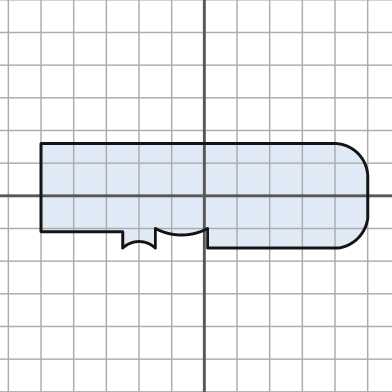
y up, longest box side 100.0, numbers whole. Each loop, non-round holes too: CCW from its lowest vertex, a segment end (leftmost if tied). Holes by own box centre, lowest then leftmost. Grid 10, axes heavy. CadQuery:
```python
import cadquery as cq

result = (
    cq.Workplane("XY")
    .moveTo(-25.0, -16.0)
    .threePointArc((-20.0, -14.0), (-15.0, -16.0))
    .lineTo(-15.0, -10.0)
    .threePointArc((-7.0, -12.0), (1.0, -10.0))
    .lineTo(1.0, -16.0)
    .lineTo(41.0, -16.0)
    .threePointArc((47.0, -13.0), (50.0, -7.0))
    .lineTo(50.0, 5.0)
    .threePointArc((47.0, 13.0), (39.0, 16.0))
    .lineTo(-50.0, 16.0)
    .lineTo(-50.0, -11.0)
    .lineTo(-25.0, -11.0)
    .close()
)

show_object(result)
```